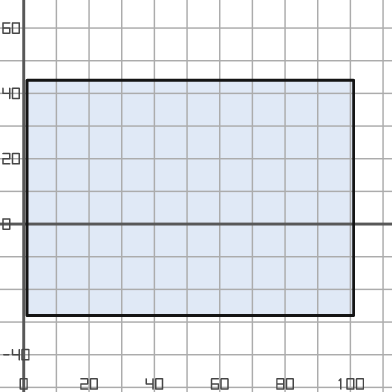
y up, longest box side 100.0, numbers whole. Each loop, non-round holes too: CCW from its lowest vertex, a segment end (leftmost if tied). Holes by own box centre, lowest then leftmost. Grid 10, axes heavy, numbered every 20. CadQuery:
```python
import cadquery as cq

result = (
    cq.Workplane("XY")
    .moveTo(1.0, -28.0)
    .lineTo(101.0, -28.0)
    .lineTo(101.0, 44.0)
    .lineTo(1.0, 44.0)
    .close()
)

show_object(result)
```